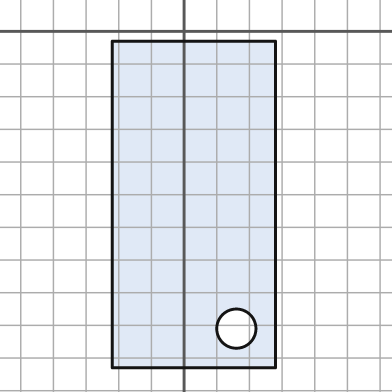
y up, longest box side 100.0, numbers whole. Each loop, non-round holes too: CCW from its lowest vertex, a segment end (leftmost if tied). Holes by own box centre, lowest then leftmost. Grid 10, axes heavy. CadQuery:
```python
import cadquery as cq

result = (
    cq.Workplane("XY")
    .moveTo(-22.0, -103.0)
    .lineTo(28.0, -103.0)
    .lineTo(28.0, -3.0)
    .lineTo(-22.0, -3.0)
    .close()
    .moveTo(16.0, -91.0)
    .circle(6.0)
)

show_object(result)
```